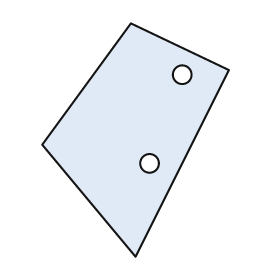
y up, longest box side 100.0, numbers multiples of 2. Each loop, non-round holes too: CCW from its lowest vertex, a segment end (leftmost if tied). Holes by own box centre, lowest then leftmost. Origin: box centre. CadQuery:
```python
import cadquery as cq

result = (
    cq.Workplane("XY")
    .moveTo(0.0, -50.0)
    .lineTo(40.0, 30.0)
    .lineTo(-2.0, 50.0)
    .lineTo(-40.0, -2.0)
    .close()
    .moveTo(6.0, -10.0)
    .circle(4.0)
    .moveTo(20.0, 28.0)
    .circle(4.0)
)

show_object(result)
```